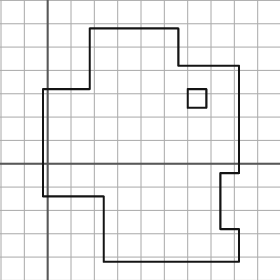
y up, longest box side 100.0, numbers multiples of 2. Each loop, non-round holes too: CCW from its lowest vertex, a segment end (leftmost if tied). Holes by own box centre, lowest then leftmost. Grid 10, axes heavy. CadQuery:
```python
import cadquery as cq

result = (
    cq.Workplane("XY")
    .moveTo(24.0, -42.0)
    .lineTo(82.0, -42.0)
    .lineTo(82.0, -28.0)
    .lineTo(74.0, -28.0)
    .lineTo(74.0, -4.0)
    .lineTo(82.0, -4.0)
    .lineTo(82.0, 42.0)
    .lineTo(56.0, 42.0)
    .lineTo(56.0, 58.0)
    .lineTo(18.0, 58.0)
    .lineTo(18.0, 32.0)
    .lineTo(-2.0, 32.0)
    .lineTo(-2.0, -14.0)
    .lineTo(24.0, -14.0)
    .close()
    .moveTo(60.0, 24.0)
    .lineTo(68.0, 24.0)
    .lineTo(68.0, 32.0)
    .lineTo(60.0, 32.0)
    .close()
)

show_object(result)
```